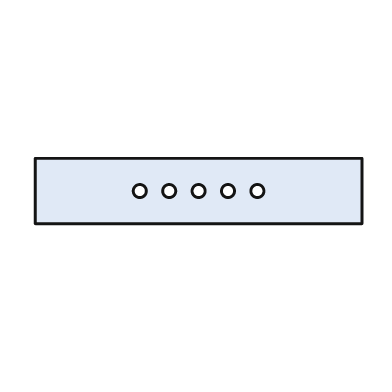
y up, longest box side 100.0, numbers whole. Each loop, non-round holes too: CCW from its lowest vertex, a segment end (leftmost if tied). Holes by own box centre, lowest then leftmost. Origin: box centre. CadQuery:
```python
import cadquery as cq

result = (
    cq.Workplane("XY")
    .moveTo(-50.0, -10.0)
    .lineTo(50.0, -10.0)
    .lineTo(50.0, 10.0)
    .lineTo(-50.0, 10.0)
    .close()
    .moveTo(-18.0, 0.0)
    .circle(2.0)
    .moveTo(-9.0, 0.0)
    .circle(2.0)
    .moveTo(0.0, 0.0)
    .circle(2.0)
    .moveTo(9.0, 0.0)
    .circle(2.0)
    .moveTo(18.0, 0.0)
    .circle(2.0)
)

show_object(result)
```